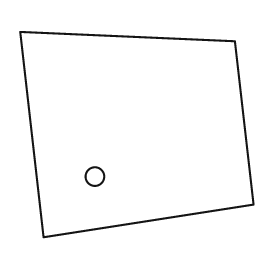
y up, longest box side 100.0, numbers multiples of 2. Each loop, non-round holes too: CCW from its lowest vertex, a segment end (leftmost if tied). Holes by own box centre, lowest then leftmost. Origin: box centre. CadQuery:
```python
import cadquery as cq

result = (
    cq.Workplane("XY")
    .moveTo(-40.0, -44.0)
    .lineTo(50.0, -30.0)
    .lineTo(42.0, 40.0)
    .lineTo(-50.0, 44.0)
    .close()
    .moveTo(-18.0, -18.0)
    .circle(4.0)
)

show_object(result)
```